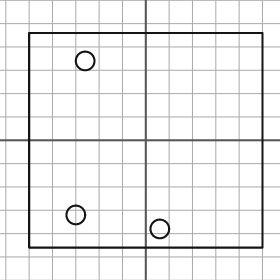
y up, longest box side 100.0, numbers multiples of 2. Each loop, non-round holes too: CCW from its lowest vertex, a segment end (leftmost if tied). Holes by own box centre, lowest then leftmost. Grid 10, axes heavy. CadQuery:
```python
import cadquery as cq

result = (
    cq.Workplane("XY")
    .moveTo(-50.0, -46.0)
    .lineTo(50.0, -46.0)
    .lineTo(50.0, 46.0)
    .lineTo(-50.0, 46.0)
    .close()
    .moveTo(6.0, -38.0)
    .circle(4.0)
    .moveTo(-30.0, -32.0)
    .circle(4.0)
    .moveTo(-26.0, 34.0)
    .circle(4.0)
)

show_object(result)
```